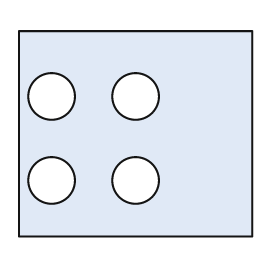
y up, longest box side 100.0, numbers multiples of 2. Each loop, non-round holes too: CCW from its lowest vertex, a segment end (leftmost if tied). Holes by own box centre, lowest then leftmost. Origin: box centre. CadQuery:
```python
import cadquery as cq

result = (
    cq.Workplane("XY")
    .moveTo(-50.0, -44.0)
    .lineTo(50.0, -44.0)
    .lineTo(50.0, 44.0)
    .lineTo(-50.0, 44.0)
    .close()
    .moveTo(-36.0, -20.0)
    .circle(10.0)
    .moveTo(0.0, -20.0)
    .circle(10.0)
    .moveTo(-36.0, 16.0)
    .circle(10.0)
    .moveTo(0.0, 16.0)
    .circle(10.0)
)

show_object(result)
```